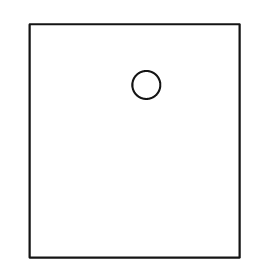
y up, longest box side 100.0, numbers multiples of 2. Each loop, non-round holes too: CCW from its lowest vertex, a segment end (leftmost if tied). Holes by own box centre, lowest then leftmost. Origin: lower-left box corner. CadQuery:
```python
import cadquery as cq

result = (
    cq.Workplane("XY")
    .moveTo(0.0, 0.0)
    .lineTo(90.0, 0.0)
    .lineTo(90.0, 100.0)
    .lineTo(0.0, 100.0)
    .close()
    .moveTo(50.0, 74.0)
    .circle(6.0)
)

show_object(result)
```